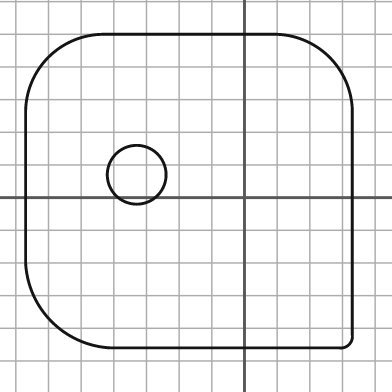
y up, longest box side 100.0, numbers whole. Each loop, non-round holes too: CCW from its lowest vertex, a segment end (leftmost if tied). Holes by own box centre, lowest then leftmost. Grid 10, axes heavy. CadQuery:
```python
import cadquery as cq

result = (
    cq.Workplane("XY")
    .moveTo(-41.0, -46.0)
    .lineTo(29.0, -46.0)
    .threePointArc((32.0, -45.0), (33.0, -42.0))
    .lineTo(33.0, 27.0)
    .threePointArc((26.0, 43.0), (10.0, 50.0))
    .lineTo(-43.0, 50.0)
    .threePointArc((-60.0, 43.0), (-67.0, 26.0))
    .lineTo(-67.0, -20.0)
    .threePointArc((-59.0, -38.0), (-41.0, -46.0))
    .close()
    .moveTo(-33.0, 7.0)
    .circle(9.0)
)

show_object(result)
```